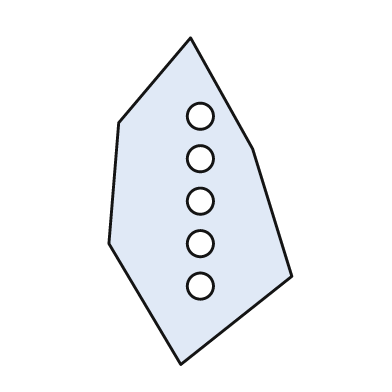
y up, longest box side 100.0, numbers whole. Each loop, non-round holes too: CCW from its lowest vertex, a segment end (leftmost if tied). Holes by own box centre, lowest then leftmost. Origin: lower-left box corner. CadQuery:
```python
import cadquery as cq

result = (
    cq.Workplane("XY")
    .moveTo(22.0, 0.0)
    .lineTo(56.0, 27.0)
    .lineTo(44.0, 66.0)
    .lineTo(25.0, 100.0)
    .lineTo(3.0, 74.0)
    .lineTo(0.0, 37.0)
    .close()
    .moveTo(28.0, 24.0)
    .circle(4.0)
    .moveTo(28.0, 37.0)
    .circle(4.0)
    .moveTo(28.0, 50.0)
    .circle(4.0)
    .moveTo(28.0, 63.0)
    .circle(4.0)
    .moveTo(28.0, 76.0)
    .circle(4.0)
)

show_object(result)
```